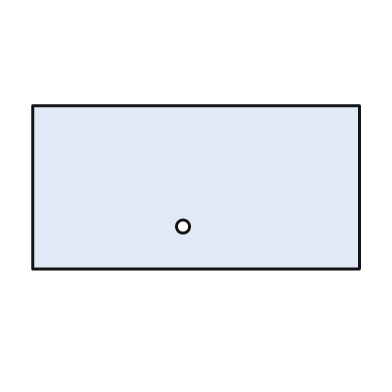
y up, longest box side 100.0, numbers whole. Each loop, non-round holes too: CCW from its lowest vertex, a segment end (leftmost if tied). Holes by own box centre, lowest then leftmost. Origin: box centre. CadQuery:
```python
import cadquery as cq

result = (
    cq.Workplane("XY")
    .moveTo(-50.0, -25.0)
    .lineTo(50.0, -25.0)
    .lineTo(50.0, 25.0)
    .lineTo(-50.0, 25.0)
    .close()
    .moveTo(-4.0, -12.0)
    .circle(2.0)
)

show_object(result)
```